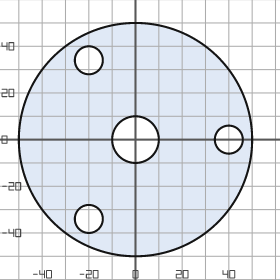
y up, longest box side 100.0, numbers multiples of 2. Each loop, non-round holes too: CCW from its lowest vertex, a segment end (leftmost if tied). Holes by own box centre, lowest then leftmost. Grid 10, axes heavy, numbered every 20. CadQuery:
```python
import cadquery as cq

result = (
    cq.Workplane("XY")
    .moveTo(0.0, 0.0)
    .circle(50.0)
    .moveTo(-20.0, -34.0)
    .circle(6.0)
    .moveTo(0.0, 0.0)
    .circle(10.0)
    .moveTo(40.0, 0.0)
    .circle(6.0)
    .moveTo(-20.0, 34.0)
    .circle(6.0)
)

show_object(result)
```